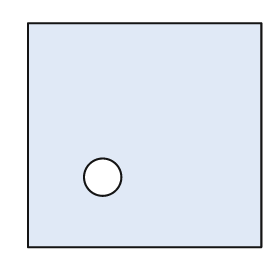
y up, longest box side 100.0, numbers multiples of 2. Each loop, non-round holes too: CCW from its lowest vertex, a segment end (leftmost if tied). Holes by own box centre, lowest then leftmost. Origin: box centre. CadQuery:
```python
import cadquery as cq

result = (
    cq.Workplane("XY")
    .moveTo(-50.0, -48.0)
    .lineTo(50.0, -48.0)
    .lineTo(50.0, 48.0)
    .lineTo(-50.0, 48.0)
    .close()
    .moveTo(-18.0, -18.0)
    .circle(8.0)
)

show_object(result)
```